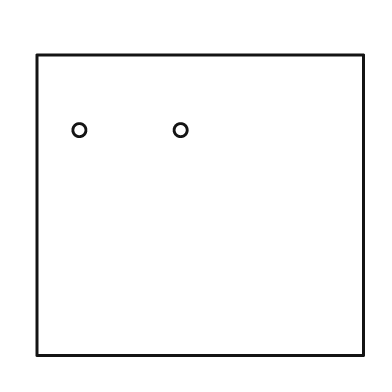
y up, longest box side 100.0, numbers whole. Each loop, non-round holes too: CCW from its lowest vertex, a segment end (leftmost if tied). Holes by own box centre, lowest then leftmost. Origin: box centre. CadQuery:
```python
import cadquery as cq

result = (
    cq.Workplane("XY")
    .moveTo(-50.0, -46.0)
    .lineTo(50.0, -46.0)
    .lineTo(50.0, 46.0)
    .lineTo(-50.0, 46.0)
    .close()
    .moveTo(-37.0, 23.0)
    .circle(2.0)
    .moveTo(-6.0, 23.0)
    .circle(2.0)
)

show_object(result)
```